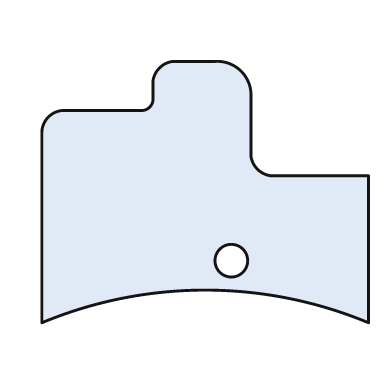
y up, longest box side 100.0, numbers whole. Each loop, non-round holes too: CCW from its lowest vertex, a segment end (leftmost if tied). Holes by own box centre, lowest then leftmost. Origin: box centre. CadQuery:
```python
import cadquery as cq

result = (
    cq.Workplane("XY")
    .moveTo(-50.0, -40.0)
    .threePointArc((0.0, -30.0), (50.0, -40.0))
    .lineTo(50.0, 5.0)
    .lineTo(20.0, 5.0)
    .threePointArc((16.0, 7.0), (14.0, 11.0))
    .lineTo(14.0, 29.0)
    .threePointArc((11.0, 37.0), (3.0, 40.0))
    .lineTo(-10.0, 40.0)
    .threePointArc((-14.0, 38.0), (-16.0, 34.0))
    .lineTo(-16.0, 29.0)
    .threePointArc((-17.0, 26.0), (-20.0, 25.0))
    .lineTo(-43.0, 25.0)
    .threePointArc((-48.0, 23.0), (-50.0, 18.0))
    .close()
    .moveTo(8.0, -21.0)
    .circle(5.0)
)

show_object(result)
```